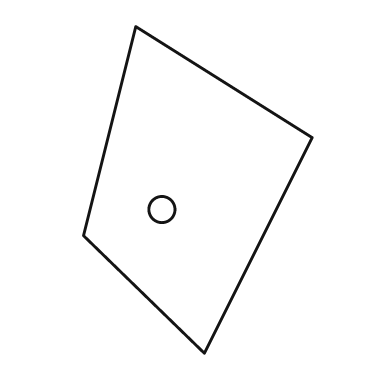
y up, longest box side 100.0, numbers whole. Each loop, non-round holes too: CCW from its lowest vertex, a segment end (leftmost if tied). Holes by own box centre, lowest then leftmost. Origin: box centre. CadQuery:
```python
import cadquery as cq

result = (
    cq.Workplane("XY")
    .moveTo(2.0, -50.0)
    .lineTo(35.0, 16.0)
    .lineTo(-19.0, 50.0)
    .lineTo(-35.0, -14.0)
    .close()
    .moveTo(-11.0, -6.0)
    .circle(4.0)
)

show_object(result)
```